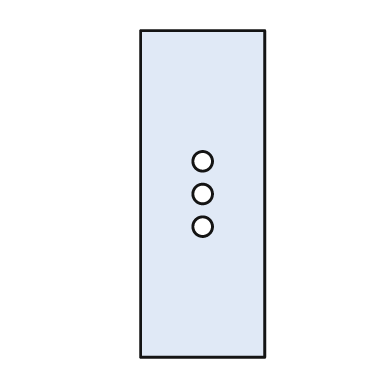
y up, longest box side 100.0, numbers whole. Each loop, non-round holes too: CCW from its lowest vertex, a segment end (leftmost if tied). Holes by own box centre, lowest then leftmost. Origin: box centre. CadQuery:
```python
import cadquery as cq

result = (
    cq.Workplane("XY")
    .moveTo(-19.0, -50.0)
    .lineTo(19.0, -50.0)
    .lineTo(19.0, 50.0)
    .lineTo(-19.0, 50.0)
    .close()
    .moveTo(0.0, -10.0)
    .circle(3.0)
    .moveTo(0.0, 0.0)
    .circle(3.0)
    .moveTo(0.0, 10.0)
    .circle(3.0)
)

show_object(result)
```